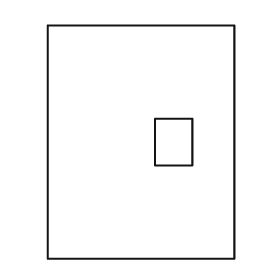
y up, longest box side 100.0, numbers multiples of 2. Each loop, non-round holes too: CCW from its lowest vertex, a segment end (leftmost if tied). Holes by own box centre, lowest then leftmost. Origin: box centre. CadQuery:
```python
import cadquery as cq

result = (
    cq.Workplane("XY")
    .moveTo(-40.0, -50.0)
    .lineTo(40.0, -50.0)
    .lineTo(40.0, 50.0)
    .lineTo(-40.0, 50.0)
    .close()
    .moveTo(6.0, -10.0)
    .lineTo(22.0, -10.0)
    .lineTo(22.0, 10.0)
    .lineTo(6.0, 10.0)
    .close()
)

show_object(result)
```